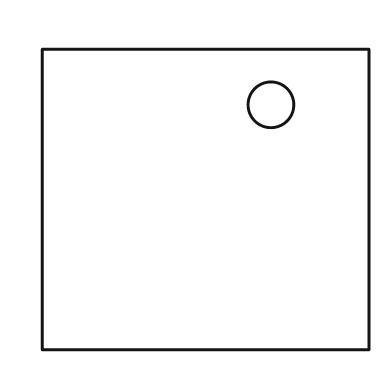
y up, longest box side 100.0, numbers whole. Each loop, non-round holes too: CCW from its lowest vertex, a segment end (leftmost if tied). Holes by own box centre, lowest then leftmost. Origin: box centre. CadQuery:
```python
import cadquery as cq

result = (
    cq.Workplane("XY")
    .moveTo(-50.0, -46.0)
    .lineTo(50.0, -46.0)
    .lineTo(50.0, 46.0)
    .lineTo(-50.0, 46.0)
    .close()
    .moveTo(20.0, 29.0)
    .circle(7.0)
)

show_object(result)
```